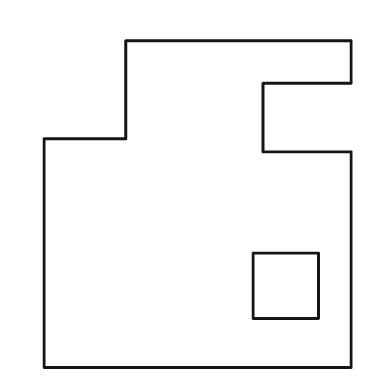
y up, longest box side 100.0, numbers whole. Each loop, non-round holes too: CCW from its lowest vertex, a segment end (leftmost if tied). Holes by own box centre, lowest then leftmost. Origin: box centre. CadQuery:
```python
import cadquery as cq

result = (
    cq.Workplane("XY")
    .moveTo(-47.0, -50.0)
    .lineTo(47.0, -50.0)
    .lineTo(47.0, 16.0)
    .lineTo(20.0, 16.0)
    .lineTo(20.0, 37.0)
    .lineTo(47.0, 37.0)
    .lineTo(47.0, 50.0)
    .lineTo(-22.0, 50.0)
    .lineTo(-22.0, 20.0)
    .lineTo(-47.0, 20.0)
    .close()
    .moveTo(17.0, -35.0)
    .lineTo(37.0, -35.0)
    .lineTo(37.0, -15.0)
    .lineTo(17.0, -15.0)
    .close()
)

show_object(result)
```